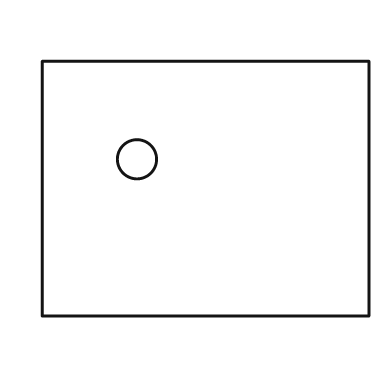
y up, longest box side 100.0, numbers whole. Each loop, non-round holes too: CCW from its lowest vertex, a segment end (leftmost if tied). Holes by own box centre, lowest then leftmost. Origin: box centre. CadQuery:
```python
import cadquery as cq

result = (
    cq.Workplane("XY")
    .moveTo(-50.0, -39.0)
    .lineTo(50.0, -39.0)
    .lineTo(50.0, 39.0)
    .lineTo(-50.0, 39.0)
    .close()
    .moveTo(-21.0, 9.0)
    .circle(6.0)
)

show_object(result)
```